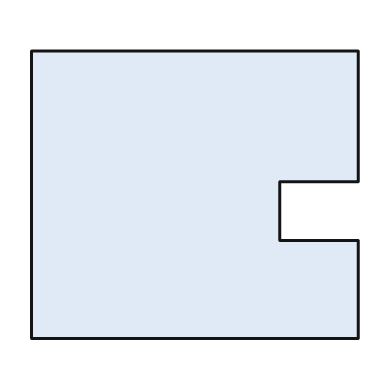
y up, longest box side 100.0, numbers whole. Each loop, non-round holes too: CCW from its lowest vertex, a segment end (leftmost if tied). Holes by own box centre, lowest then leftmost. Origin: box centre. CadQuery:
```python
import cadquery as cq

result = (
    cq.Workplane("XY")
    .moveTo(-50.0, -44.0)
    .lineTo(50.0, -44.0)
    .lineTo(50.0, -14.0)
    .lineTo(26.0, -14.0)
    .lineTo(26.0, 4.0)
    .lineTo(50.0, 4.0)
    .lineTo(50.0, 44.0)
    .lineTo(-50.0, 44.0)
    .close()
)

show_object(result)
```